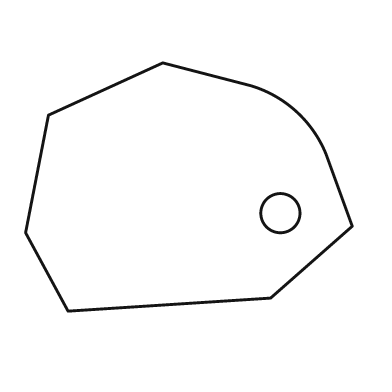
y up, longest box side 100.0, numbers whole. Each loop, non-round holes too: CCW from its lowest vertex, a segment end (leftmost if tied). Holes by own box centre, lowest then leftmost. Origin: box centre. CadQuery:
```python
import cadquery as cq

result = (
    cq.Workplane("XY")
    .moveTo(-37.0, -38.0)
    .lineTo(25.0, -34.0)
    .lineTo(50.0, -12.0)
    .lineTo(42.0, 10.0)
    .threePointArc((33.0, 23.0), (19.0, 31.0))
    .lineTo(-8.0, 38.0)
    .lineTo(-43.0, 22.0)
    .lineTo(-50.0, -14.0)
    .close()
    .moveTo(28.0, -8.0)
    .circle(6.0)
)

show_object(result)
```